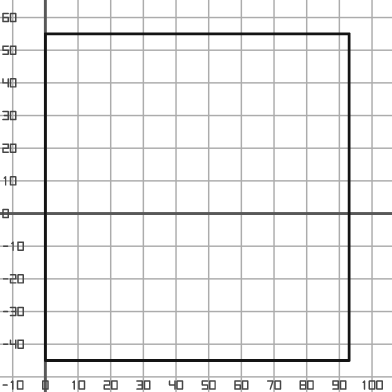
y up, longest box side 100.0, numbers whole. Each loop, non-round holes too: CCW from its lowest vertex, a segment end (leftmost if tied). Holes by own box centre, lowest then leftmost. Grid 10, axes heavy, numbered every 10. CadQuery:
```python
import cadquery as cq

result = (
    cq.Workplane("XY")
    .moveTo(0.0, -45.0)
    .lineTo(93.0, -45.0)
    .lineTo(93.0, 55.0)
    .lineTo(0.0, 55.0)
    .close()
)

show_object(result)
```